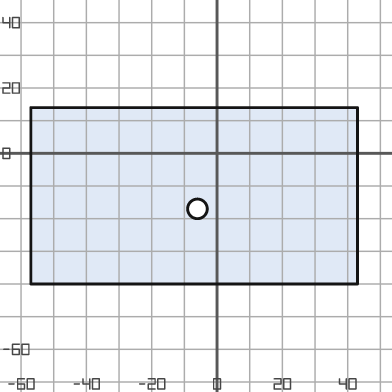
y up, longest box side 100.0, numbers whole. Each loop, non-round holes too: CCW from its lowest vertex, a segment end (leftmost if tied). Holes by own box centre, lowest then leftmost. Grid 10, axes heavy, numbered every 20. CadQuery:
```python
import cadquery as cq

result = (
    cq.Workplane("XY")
    .moveTo(-57.0, -40.0)
    .lineTo(43.0, -40.0)
    .lineTo(43.0, 14.0)
    .lineTo(-57.0, 14.0)
    .close()
    .moveTo(-6.0, -17.0)
    .circle(3.0)
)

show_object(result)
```